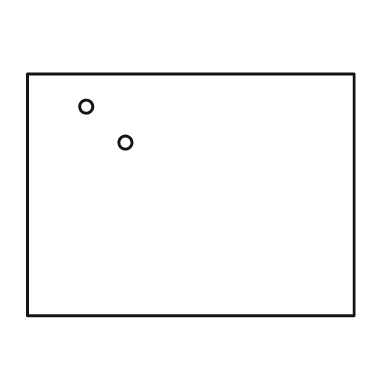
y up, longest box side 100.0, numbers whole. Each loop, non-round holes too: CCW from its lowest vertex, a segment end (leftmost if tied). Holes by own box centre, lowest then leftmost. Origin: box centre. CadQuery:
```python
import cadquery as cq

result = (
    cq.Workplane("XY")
    .moveTo(-50.0, -37.0)
    .lineTo(50.0, -37.0)
    .lineTo(50.0, 37.0)
    .lineTo(-50.0, 37.0)
    .close()
    .moveTo(-20.0, 16.0)
    .circle(2.0)
    .moveTo(-32.0, 27.0)
    .circle(2.0)
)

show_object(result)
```